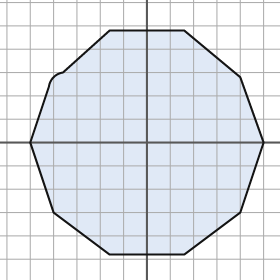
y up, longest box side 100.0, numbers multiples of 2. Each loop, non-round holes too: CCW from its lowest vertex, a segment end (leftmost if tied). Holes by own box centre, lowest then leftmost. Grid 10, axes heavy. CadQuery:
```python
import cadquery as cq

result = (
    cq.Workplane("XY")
    .moveTo(-16.0, -48.0)
    .lineTo(16.0, -48.0)
    .lineTo(40.0, -30.0)
    .lineTo(50.0, 0.0)
    .lineTo(40.0, 28.0)
    .lineTo(16.0, 48.0)
    .lineTo(-16.0, 48.0)
    .lineTo(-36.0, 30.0)
    .threePointArc((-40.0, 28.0), (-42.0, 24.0))
    .lineTo(-50.0, 0.0)
    .lineTo(-40.0, -30.0)
    .close()
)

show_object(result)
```